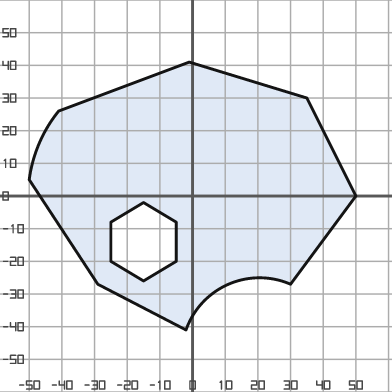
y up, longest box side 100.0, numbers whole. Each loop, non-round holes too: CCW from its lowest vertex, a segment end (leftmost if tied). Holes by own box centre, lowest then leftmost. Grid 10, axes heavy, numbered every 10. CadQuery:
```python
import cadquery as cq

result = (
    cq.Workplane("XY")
    .moveTo(-2.0, -41.0)
    .threePointArc((11.0, -27.0), (30.0, -27.0))
    .lineTo(50.0, 0.0)
    .lineTo(35.0, 30.0)
    .lineTo(-1.0, 41.0)
    .lineTo(-41.0, 26.0)
    .threePointArc((-47.0, 16.0), (-50.0, 5.0))
    .lineTo(-29.0, -27.0)
    .close()
    .moveTo(-15.0, -26.0)
    .lineTo(-5.0, -20.0)
    .lineTo(-5.0, -8.0)
    .lineTo(-15.0, -2.0)
    .lineTo(-25.0, -8.0)
    .lineTo(-25.0, -20.0)
    .close()
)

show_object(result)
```